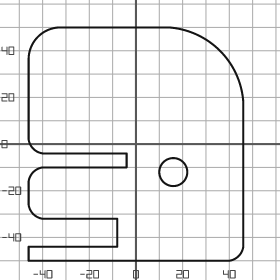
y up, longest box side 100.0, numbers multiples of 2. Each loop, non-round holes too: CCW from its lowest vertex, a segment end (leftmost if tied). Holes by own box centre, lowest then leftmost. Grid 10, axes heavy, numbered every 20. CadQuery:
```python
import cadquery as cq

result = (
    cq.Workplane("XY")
    .moveTo(-46.0, -50.0)
    .lineTo(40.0, -50.0)
    .threePointArc((44.0, -48.0), (46.0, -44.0))
    .lineTo(46.0, 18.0)
    .threePointArc((36.0, 40.0), (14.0, 50.0))
    .lineTo(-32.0, 50.0)
    .threePointArc((-42.0, 46.0), (-46.0, 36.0))
    .lineTo(-46.0, 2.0)
    .threePointArc((-44.0, -2.0), (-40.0, -4.0))
    .lineTo(-4.0, -4.0)
    .lineTo(-4.0, -10.0)
    .lineTo(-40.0, -10.0)
    .threePointArc((-44.0, -12.0), (-46.0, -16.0))
    .lineTo(-46.0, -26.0)
    .threePointArc((-44.0, -30.0), (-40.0, -32.0))
    .lineTo(-8.0, -32.0)
    .lineTo(-8.0, -44.0)
    .lineTo(-46.0, -44.0)
    .close()
    .moveTo(16.0, -12.0)
    .circle(6.0)
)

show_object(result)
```